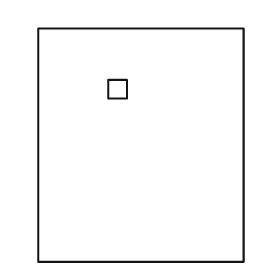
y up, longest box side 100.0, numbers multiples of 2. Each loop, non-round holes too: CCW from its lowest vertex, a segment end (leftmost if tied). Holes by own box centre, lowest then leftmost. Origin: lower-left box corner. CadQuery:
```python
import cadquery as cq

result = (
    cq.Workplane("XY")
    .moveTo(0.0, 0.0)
    .lineTo(88.0, 0.0)
    .lineTo(88.0, 100.0)
    .lineTo(0.0, 100.0)
    .close()
    .moveTo(30.0, 70.0)
    .lineTo(38.0, 70.0)
    .lineTo(38.0, 78.0)
    .lineTo(30.0, 78.0)
    .close()
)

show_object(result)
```